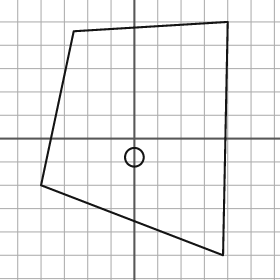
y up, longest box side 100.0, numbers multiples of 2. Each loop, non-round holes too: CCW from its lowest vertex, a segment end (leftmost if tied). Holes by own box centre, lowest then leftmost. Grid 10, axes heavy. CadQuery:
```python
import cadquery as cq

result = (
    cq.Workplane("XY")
    .moveTo(38.0, -50.0)
    .lineTo(40.0, 50.0)
    .lineTo(-26.0, 46.0)
    .lineTo(-40.0, -20.0)
    .close()
    .moveTo(0.0, -8.0)
    .circle(4.0)
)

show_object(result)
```